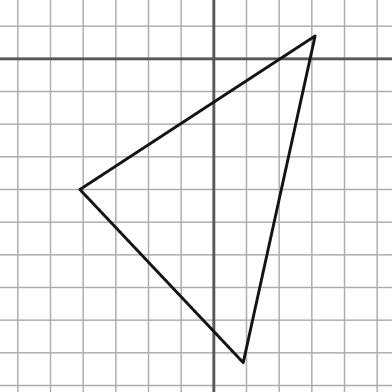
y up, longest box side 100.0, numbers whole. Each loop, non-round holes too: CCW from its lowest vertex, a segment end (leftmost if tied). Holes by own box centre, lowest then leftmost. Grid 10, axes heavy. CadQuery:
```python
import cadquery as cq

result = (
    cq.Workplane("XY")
    .moveTo(9.0, -93.0)
    .lineTo(31.0, 7.0)
    .lineTo(-41.0, -40.0)
    .close()
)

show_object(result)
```